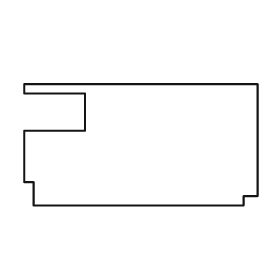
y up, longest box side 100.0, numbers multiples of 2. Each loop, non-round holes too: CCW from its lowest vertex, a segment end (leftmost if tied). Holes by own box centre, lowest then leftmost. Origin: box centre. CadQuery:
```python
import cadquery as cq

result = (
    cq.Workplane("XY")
    .moveTo(-46.0, -26.0)
    .lineTo(44.0, -26.0)
    .lineTo(44.0, -22.0)
    .lineTo(50.0, -22.0)
    .lineTo(50.0, 26.0)
    .lineTo(-50.0, 26.0)
    .lineTo(-50.0, 22.0)
    .lineTo(-24.0, 22.0)
    .lineTo(-24.0, 6.0)
    .lineTo(-50.0, 6.0)
    .lineTo(-50.0, -16.0)
    .lineTo(-46.0, -16.0)
    .close()
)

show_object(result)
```